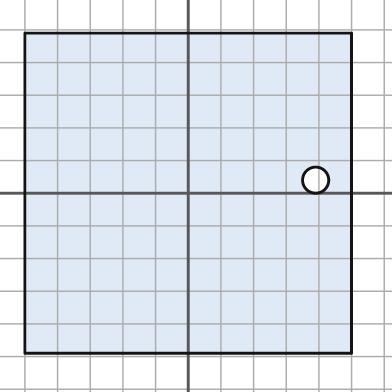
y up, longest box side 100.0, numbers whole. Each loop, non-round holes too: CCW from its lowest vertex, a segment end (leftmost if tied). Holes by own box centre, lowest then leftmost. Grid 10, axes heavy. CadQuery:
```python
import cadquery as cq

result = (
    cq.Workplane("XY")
    .moveTo(-50.0, -49.0)
    .lineTo(50.0, -49.0)
    .lineTo(50.0, 49.0)
    .lineTo(-50.0, 49.0)
    .close()
    .moveTo(39.0, 4.0)
    .circle(4.0)
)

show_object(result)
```